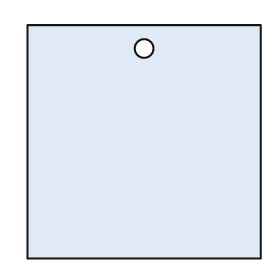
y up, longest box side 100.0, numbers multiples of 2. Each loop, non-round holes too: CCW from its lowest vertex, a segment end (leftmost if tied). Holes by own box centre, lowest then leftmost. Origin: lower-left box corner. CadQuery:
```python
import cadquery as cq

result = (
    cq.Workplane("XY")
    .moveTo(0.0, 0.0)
    .lineTo(100.0, 0.0)
    .lineTo(100.0, 100.0)
    .lineTo(0.0, 100.0)
    .close()
    .moveTo(50.0, 90.0)
    .circle(4.0)
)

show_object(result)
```